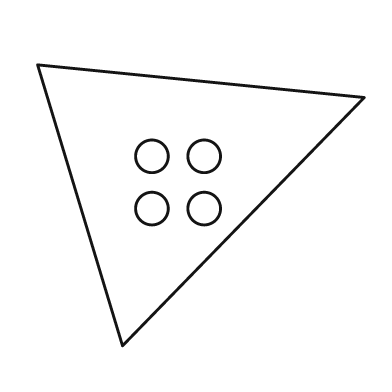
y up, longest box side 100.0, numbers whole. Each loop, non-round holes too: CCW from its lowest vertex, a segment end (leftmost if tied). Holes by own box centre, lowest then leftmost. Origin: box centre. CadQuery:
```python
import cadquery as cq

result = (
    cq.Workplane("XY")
    .moveTo(-24.0, -43.0)
    .lineTo(50.0, 33.0)
    .lineTo(-50.0, 43.0)
    .close()
    .moveTo(-15.0, -1.0)
    .circle(5.0)
    .moveTo(1.0, -1.0)
    .circle(5.0)
    .moveTo(-15.0, 15.0)
    .circle(5.0)
    .moveTo(1.0, 15.0)
    .circle(5.0)
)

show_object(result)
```